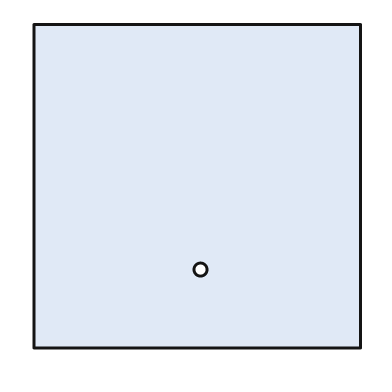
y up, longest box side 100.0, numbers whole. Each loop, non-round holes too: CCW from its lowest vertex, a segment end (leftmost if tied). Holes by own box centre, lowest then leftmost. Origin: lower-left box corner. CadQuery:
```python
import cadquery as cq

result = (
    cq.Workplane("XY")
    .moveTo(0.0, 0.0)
    .lineTo(100.0, 0.0)
    .lineTo(100.0, 99.0)
    .lineTo(0.0, 99.0)
    .close()
    .moveTo(51.0, 24.0)
    .circle(2.0)
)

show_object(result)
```